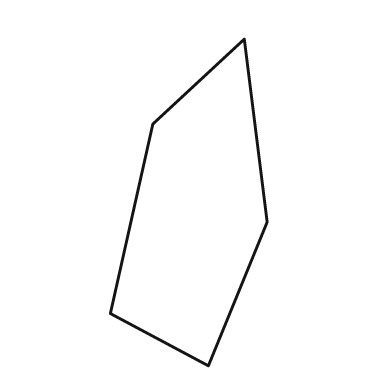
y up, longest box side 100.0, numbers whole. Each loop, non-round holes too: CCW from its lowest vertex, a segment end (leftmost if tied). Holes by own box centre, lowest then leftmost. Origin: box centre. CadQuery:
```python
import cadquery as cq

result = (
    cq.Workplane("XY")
    .moveTo(6.0, -50.0)
    .lineTo(24.0, -6.0)
    .lineTo(17.0, 50.0)
    .lineTo(-11.0, 24.0)
    .lineTo(-24.0, -34.0)
    .close()
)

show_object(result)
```